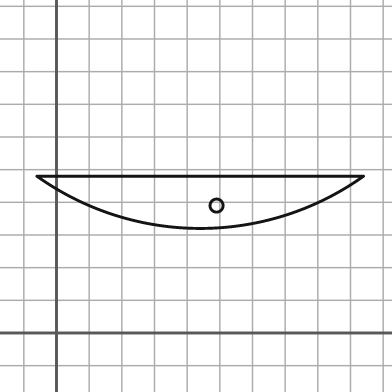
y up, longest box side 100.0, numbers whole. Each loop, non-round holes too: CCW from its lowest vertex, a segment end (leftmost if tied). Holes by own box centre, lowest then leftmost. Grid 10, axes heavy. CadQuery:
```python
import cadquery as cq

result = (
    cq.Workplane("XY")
    .moveTo(-6.0, 48.0)
    .threePointArc((44.0, 32.0), (94.0, 48.0))
    .close()
    .moveTo(49.0, 39.0)
    .circle(2.0)
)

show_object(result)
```